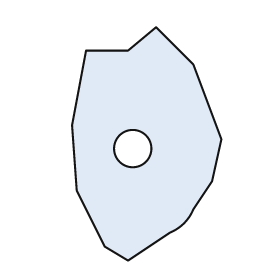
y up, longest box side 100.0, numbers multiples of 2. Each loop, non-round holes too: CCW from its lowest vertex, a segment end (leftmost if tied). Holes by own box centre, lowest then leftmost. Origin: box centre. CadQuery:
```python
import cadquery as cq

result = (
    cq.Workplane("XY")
    .moveTo(-8.0, -50.0)
    .lineTo(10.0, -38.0)
    .threePointArc((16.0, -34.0), (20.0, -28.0))
    .lineTo(28.0, -16.0)
    .lineTo(32.0, 2.0)
    .lineTo(20.0, 34.0)
    .lineTo(4.0, 50.0)
    .lineTo(-8.0, 40.0)
    .lineTo(-26.0, 40.0)
    .lineTo(-32.0, 8.0)
    .lineTo(-30.0, -20.0)
    .lineTo(-18.0, -44.0)
    .close()
    .moveTo(-6.0, -2.0)
    .circle(8.0)
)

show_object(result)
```